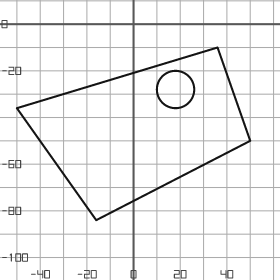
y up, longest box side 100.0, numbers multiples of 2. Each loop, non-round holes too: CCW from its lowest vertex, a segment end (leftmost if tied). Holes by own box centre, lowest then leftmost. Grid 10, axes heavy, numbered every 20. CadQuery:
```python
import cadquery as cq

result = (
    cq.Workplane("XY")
    .moveTo(-16.0, -84.0)
    .lineTo(50.0, -50.0)
    .lineTo(36.0, -10.0)
    .lineTo(-50.0, -36.0)
    .close()
    .moveTo(18.0, -28.0)
    .circle(8.0)
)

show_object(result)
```